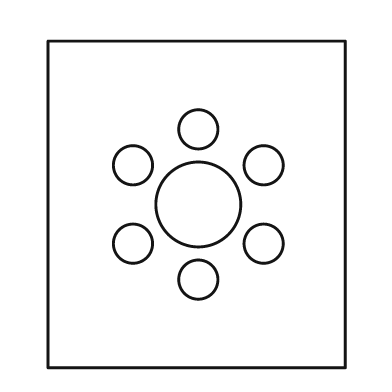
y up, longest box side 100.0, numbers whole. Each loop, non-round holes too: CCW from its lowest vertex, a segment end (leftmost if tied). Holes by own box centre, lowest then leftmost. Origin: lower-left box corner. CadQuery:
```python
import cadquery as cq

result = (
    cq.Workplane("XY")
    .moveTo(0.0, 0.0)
    .lineTo(91.0, 0.0)
    .lineTo(91.0, 100.0)
    .lineTo(0.0, 100.0)
    .close()
    .moveTo(46.0, 27.0)
    .circle(6.0)
    .moveTo(26.0, 38.0)
    .circle(6.0)
    .moveTo(66.0, 38.0)
    .circle(6.0)
    .moveTo(46.0, 50.0)
    .circle(13.0)
    .moveTo(26.0, 62.0)
    .circle(6.0)
    .moveTo(66.0, 62.0)
    .circle(6.0)
    .moveTo(46.0, 73.0)
    .circle(6.0)
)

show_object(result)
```